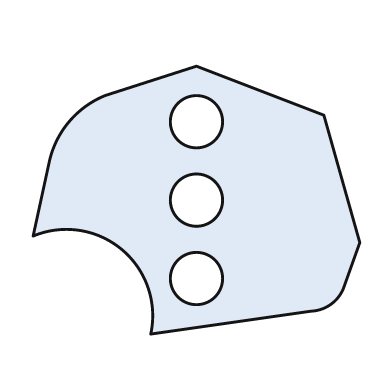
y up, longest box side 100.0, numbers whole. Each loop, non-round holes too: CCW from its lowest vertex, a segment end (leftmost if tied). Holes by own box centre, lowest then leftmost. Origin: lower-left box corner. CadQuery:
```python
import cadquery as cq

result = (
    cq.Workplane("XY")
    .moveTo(36.0, 0.0)
    .lineTo(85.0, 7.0)
    .threePointArc((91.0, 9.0), (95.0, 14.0))
    .lineTo(100.0, 28.0)
    .lineTo(89.0, 67.0)
    .lineTo(50.0, 82.0)
    .lineTo(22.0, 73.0)
    .threePointArc((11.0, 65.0), (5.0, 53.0))
    .lineTo(0.0, 30.0)
    .threePointArc((27.0, 26.0), (36.0, 0.0))
    .close()
    .moveTo(50.0, 17.0)
    .circle(8.0)
    .moveTo(50.0, 41.0)
    .circle(8.0)
    .moveTo(50.0, 65.0)
    .circle(8.0)
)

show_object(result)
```